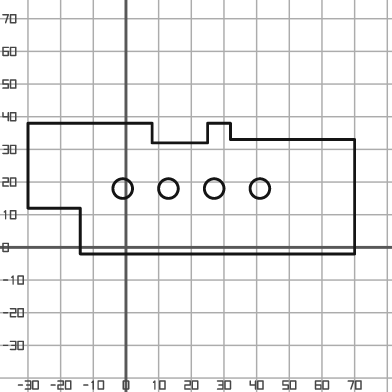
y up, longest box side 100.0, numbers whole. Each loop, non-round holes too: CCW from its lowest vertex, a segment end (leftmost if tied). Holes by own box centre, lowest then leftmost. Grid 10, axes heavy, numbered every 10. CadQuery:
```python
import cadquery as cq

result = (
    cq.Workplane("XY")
    .moveTo(-14.0, -2.0)
    .lineTo(70.0, -2.0)
    .lineTo(70.0, 33.0)
    .lineTo(32.0, 33.0)
    .lineTo(32.0, 38.0)
    .lineTo(25.0, 38.0)
    .lineTo(25.0, 32.0)
    .lineTo(8.0, 32.0)
    .lineTo(8.0, 38.0)
    .lineTo(-30.0, 38.0)
    .lineTo(-30.0, 12.0)
    .lineTo(-14.0, 12.0)
    .close()
    .moveTo(-1.0, 18.0)
    .circle(3.0)
    .moveTo(13.0, 18.0)
    .circle(3.0)
    .moveTo(27.0, 18.0)
    .circle(3.0)
    .moveTo(41.0, 18.0)
    .circle(3.0)
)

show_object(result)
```